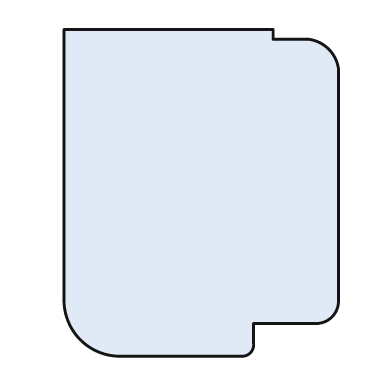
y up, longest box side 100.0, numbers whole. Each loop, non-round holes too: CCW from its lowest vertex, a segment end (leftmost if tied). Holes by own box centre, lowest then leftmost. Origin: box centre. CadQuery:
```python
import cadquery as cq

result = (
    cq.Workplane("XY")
    .moveTo(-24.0, -50.0)
    .lineTo(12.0, -50.0)
    .threePointArc((15.0, -49.0), (16.0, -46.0))
    .lineTo(16.0, -40.0)
    .lineTo(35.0, -40.0)
    .threePointArc((40.0, -38.0), (42.0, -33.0))
    .lineTo(42.0, 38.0)
    .threePointArc((39.0, 44.0), (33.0, 47.0))
    .lineTo(22.0, 47.0)
    .lineTo(22.0, 50.0)
    .lineTo(-42.0, 50.0)
    .lineTo(-42.0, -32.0)
    .threePointArc((-37.0, -45.0), (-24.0, -50.0))
    .close()
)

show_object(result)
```